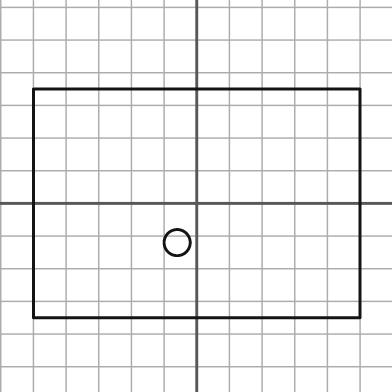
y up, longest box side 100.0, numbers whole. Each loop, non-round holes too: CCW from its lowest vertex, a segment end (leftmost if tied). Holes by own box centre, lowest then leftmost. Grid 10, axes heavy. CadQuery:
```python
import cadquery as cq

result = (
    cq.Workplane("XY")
    .moveTo(-50.0, -35.0)
    .lineTo(50.0, -35.0)
    .lineTo(50.0, 35.0)
    .lineTo(-50.0, 35.0)
    .close()
    .moveTo(-6.0, -12.0)
    .circle(4.0)
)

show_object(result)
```